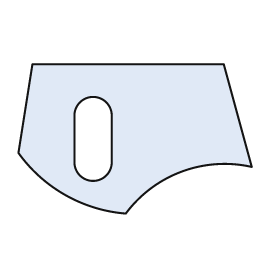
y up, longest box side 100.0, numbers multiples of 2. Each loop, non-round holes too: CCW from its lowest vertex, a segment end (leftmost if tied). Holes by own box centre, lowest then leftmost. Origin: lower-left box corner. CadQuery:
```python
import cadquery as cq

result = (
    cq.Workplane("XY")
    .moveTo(46.0, 0.0)
    .threePointArc((70.0, 18.0), (100.0, 20.0))
    .lineTo(88.0, 64.0)
    .lineTo(6.0, 64.0)
    .lineTo(0.0, 26.0)
    .threePointArc((20.0, 8.0), (46.0, 0.0))
    .close()
    .moveTo(24.0, 22.0)
    .threePointArc((32.0, 14.0), (40.0, 22.0))
    .lineTo(40.0, 42.0)
    .threePointArc((32.0, 50.0), (24.0, 42.0))
    .close()
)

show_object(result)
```